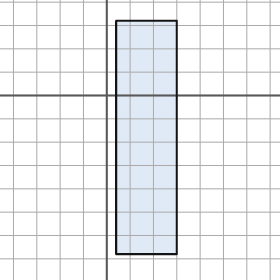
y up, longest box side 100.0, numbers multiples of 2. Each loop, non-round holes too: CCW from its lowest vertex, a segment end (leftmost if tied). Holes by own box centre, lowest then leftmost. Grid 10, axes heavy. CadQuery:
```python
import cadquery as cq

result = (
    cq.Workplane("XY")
    .moveTo(4.0, -68.0)
    .lineTo(30.0, -68.0)
    .lineTo(30.0, 32.0)
    .lineTo(4.0, 32.0)
    .close()
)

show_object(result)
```